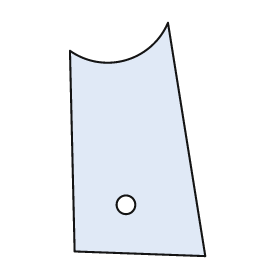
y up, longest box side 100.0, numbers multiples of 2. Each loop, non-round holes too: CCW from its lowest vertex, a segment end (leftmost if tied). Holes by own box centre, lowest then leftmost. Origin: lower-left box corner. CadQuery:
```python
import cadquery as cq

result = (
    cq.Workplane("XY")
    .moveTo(58.0, 0.0)
    .lineTo(42.0, 100.0)
    .threePointArc((24.0, 84.0), (0.0, 88.0))
    .lineTo(2.0, 2.0)
    .close()
    .moveTo(24.0, 22.0)
    .circle(4.0)
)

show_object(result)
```